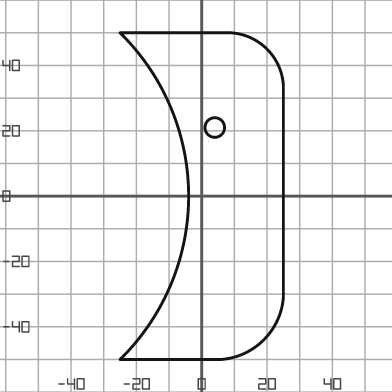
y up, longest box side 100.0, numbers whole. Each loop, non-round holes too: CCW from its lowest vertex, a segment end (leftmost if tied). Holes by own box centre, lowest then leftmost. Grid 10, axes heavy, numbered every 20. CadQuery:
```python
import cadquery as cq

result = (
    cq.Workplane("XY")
    .moveTo(-25.0, -50.0)
    .lineTo(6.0, -50.0)
    .threePointArc((19.0, -44.0), (25.0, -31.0))
    .lineTo(25.0, 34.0)
    .threePointArc((20.0, 45.0), (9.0, 50.0))
    .lineTo(-25.0, 50.0)
    .threePointArc((-4.0, 0.0), (-25.0, -50.0))
    .close()
    .moveTo(4.0, 21.0)
    .circle(3.0)
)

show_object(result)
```